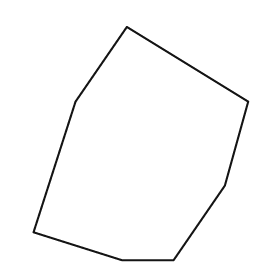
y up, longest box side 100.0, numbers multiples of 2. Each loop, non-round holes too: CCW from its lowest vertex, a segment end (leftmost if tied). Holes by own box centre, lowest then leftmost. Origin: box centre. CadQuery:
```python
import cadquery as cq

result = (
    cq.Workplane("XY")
    .moveTo(-8.0, -50.0)
    .lineTo(14.0, -50.0)
    .lineTo(36.0, -18.0)
    .lineTo(46.0, 18.0)
    .lineTo(-6.0, 50.0)
    .lineTo(-28.0, 18.0)
    .lineTo(-46.0, -38.0)
    .close()
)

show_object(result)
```